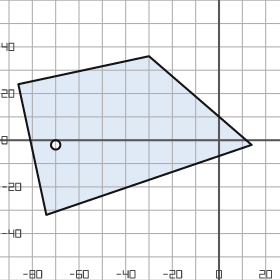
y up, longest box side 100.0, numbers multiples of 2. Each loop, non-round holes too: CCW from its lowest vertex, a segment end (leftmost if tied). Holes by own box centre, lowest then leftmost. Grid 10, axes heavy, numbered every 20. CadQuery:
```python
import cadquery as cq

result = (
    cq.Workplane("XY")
    .moveTo(-74.0, -32.0)
    .lineTo(14.0, -2.0)
    .lineTo(-30.0, 36.0)
    .lineTo(-86.0, 24.0)
    .close()
    .moveTo(-70.0, -2.0)
    .circle(2.0)
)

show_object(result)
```